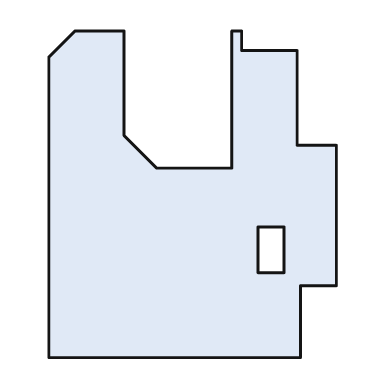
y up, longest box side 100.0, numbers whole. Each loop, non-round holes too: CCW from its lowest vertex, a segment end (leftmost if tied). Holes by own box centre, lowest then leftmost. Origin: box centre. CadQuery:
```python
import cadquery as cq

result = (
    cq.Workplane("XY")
    .moveTo(-44.0, -50.0)
    .lineTo(33.0, -50.0)
    .lineTo(33.0, -28.0)
    .lineTo(44.0, -28.0)
    .lineTo(44.0, 15.0)
    .lineTo(32.0, 15.0)
    .lineTo(32.0, 44.0)
    .lineTo(15.0, 44.0)
    .lineTo(15.0, 50.0)
    .lineTo(12.0, 50.0)
    .lineTo(12.0, 8.0)
    .lineTo(-11.0, 8.0)
    .lineTo(-21.0, 18.0)
    .lineTo(-21.0, 50.0)
    .lineTo(-36.0, 50.0)
    .lineTo(-44.0, 42.0)
    .close()
    .moveTo(20.0, -24.0)
    .lineTo(28.0, -24.0)
    .lineTo(28.0, -10.0)
    .lineTo(20.0, -10.0)
    .close()
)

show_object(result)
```